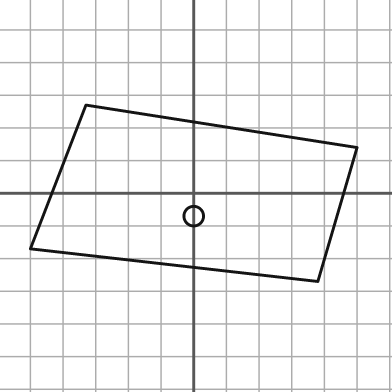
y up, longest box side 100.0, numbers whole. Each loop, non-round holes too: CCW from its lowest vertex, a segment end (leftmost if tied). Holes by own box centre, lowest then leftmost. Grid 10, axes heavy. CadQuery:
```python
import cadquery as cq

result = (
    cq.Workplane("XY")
    .moveTo(38.0, -27.0)
    .lineTo(50.0, 14.0)
    .lineTo(-33.0, 27.0)
    .lineTo(-50.0, -17.0)
    .close()
    .moveTo(0.0, -7.0)
    .circle(3.0)
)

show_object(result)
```